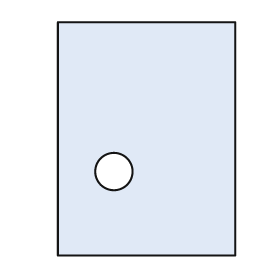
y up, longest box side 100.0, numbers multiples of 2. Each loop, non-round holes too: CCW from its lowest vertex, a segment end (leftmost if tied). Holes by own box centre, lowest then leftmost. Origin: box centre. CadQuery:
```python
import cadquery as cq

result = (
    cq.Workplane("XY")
    .moveTo(-38.0, -50.0)
    .lineTo(38.0, -50.0)
    .lineTo(38.0, 50.0)
    .lineTo(-38.0, 50.0)
    .close()
    .moveTo(-14.0, -14.0)
    .circle(8.0)
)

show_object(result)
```